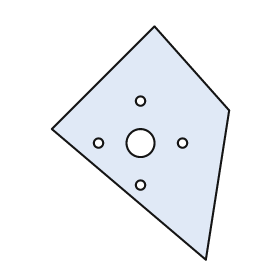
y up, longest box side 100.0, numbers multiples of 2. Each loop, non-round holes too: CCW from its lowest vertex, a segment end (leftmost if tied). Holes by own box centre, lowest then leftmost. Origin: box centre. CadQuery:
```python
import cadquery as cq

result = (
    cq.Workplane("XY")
    .moveTo(28.0, -50.0)
    .lineTo(38.0, 14.0)
    .lineTo(6.0, 50.0)
    .lineTo(-38.0, 6.0)
    .close()
    .moveTo(0.0, -18.0)
    .circle(2.0)
    .moveTo(-18.0, 0.0)
    .circle(2.0)
    .moveTo(0.0, 0.0)
    .circle(6.0)
    .moveTo(18.0, 0.0)
    .circle(2.0)
    .moveTo(0.0, 18.0)
    .circle(2.0)
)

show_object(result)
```